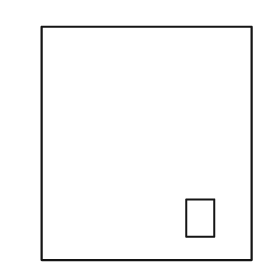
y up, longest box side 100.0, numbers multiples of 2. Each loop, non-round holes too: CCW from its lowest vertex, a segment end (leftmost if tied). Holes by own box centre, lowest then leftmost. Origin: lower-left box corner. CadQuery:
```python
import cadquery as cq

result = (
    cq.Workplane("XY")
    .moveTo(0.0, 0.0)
    .lineTo(90.0, 0.0)
    .lineTo(90.0, 100.0)
    .lineTo(0.0, 100.0)
    .close()
    .moveTo(62.0, 10.0)
    .lineTo(74.0, 10.0)
    .lineTo(74.0, 26.0)
    .lineTo(62.0, 26.0)
    .close()
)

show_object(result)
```